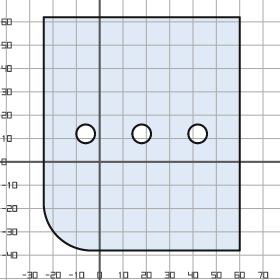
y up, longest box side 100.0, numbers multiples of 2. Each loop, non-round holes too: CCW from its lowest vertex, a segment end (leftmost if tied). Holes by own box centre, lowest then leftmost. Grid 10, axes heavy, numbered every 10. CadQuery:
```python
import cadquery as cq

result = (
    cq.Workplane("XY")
    .moveTo(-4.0, -38.0)
    .lineTo(60.0, -38.0)
    .lineTo(60.0, 62.0)
    .lineTo(-24.0, 62.0)
    .lineTo(-24.0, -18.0)
    .threePointArc((-18.0, -32.0), (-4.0, -38.0))
    .close()
    .moveTo(-6.0, 12.0)
    .circle(4.0)
    .moveTo(18.0, 12.0)
    .circle(4.0)
    .moveTo(42.0, 12.0)
    .circle(4.0)
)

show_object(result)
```